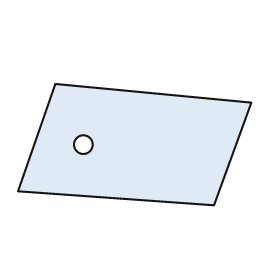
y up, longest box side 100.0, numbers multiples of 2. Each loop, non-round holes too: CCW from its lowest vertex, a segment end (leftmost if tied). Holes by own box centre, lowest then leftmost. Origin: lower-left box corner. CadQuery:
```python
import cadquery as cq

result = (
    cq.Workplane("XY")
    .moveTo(84.0, 0.0)
    .lineTo(100.0, 44.0)
    .lineTo(16.0, 52.0)
    .lineTo(0.0, 6.0)
    .close()
    .moveTo(28.0, 26.0)
    .circle(4.0)
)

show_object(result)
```